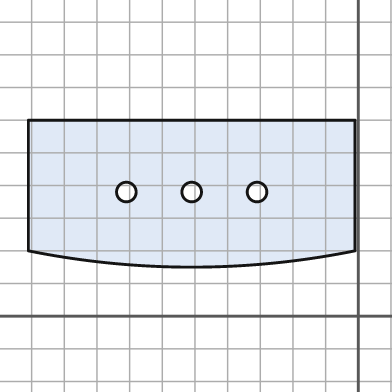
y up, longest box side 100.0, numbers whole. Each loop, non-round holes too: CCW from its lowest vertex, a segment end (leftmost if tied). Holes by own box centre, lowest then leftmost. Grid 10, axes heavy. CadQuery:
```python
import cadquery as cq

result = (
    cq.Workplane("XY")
    .moveTo(-101.0, 20.0)
    .threePointArc((-51.0, 15.0), (-1.0, 20.0))
    .lineTo(-1.0, 60.0)
    .lineTo(-101.0, 60.0)
    .close()
    .moveTo(-71.0, 38.0)
    .circle(3.0)
    .moveTo(-51.0, 38.0)
    .circle(3.0)
    .moveTo(-31.0, 38.0)
    .circle(3.0)
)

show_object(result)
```